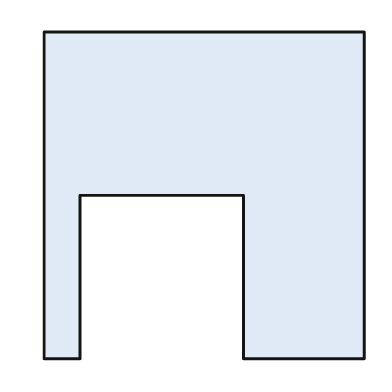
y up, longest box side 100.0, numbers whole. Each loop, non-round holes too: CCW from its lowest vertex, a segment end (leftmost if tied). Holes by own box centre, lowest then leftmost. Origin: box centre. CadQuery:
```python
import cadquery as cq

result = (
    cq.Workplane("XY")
    .moveTo(-49.0, -50.0)
    .lineTo(-38.0, -50.0)
    .lineTo(-38.0, 0.0)
    .lineTo(12.0, 0.0)
    .lineTo(12.0, -50.0)
    .lineTo(49.0, -50.0)
    .lineTo(49.0, 50.0)
    .lineTo(-49.0, 50.0)
    .close()
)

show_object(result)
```